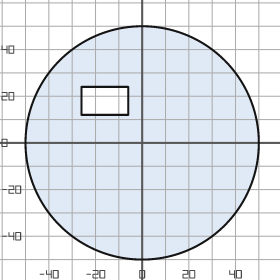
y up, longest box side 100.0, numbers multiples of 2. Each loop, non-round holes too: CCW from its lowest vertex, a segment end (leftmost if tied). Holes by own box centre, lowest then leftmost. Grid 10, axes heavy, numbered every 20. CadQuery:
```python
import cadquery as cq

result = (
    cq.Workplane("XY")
    .moveTo(0.0, 0.0)
    .circle(50.0)
    .moveTo(-26.0, 12.0)
    .lineTo(-6.0, 12.0)
    .lineTo(-6.0, 24.0)
    .lineTo(-26.0, 24.0)
    .close()
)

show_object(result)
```